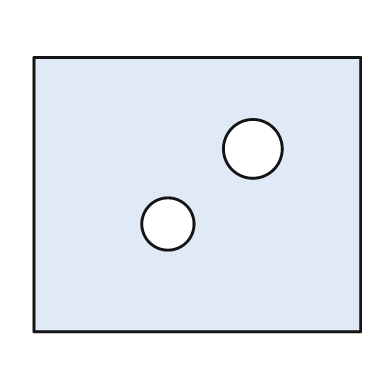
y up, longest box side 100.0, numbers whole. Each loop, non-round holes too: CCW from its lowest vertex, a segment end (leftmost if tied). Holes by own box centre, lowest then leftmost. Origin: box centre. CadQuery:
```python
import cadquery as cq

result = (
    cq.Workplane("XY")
    .moveTo(-50.0, -42.0)
    .lineTo(50.0, -42.0)
    .lineTo(50.0, 42.0)
    .lineTo(-50.0, 42.0)
    .close()
    .moveTo(-9.0, -9.0)
    .circle(8.0)
    .moveTo(17.0, 14.0)
    .circle(9.0)
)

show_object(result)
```